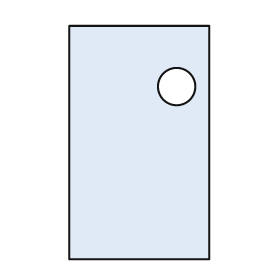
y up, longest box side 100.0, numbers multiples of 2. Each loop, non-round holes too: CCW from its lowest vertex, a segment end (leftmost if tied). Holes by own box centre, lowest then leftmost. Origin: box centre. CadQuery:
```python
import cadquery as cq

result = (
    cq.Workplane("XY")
    .moveTo(-30.0, -50.0)
    .lineTo(30.0, -50.0)
    .lineTo(30.0, 50.0)
    .lineTo(-30.0, 50.0)
    .close()
    .moveTo(16.0, 24.0)
    .circle(8.0)
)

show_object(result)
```